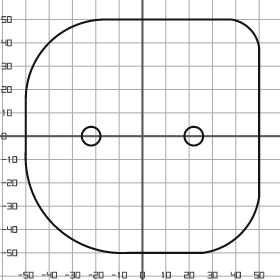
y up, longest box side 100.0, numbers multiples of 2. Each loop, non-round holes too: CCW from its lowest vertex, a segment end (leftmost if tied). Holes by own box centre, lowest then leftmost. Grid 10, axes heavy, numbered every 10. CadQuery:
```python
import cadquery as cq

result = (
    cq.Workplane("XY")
    .moveTo(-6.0, -50.0)
    .lineTo(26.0, -50.0)
    .threePointArc((42.0, -42.0), (50.0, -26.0))
    .lineTo(50.0, 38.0)
    .threePointArc((46.0, 46.0), (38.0, 50.0))
    .lineTo(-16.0, 50.0)
    .threePointArc((-40.0, 40.0), (-50.0, 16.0))
    .lineTo(-50.0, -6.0)
    .threePointArc((-38.0, -38.0), (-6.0, -50.0))
    .close()
    .moveTo(-22.0, 0.0)
    .circle(4.0)
    .moveTo(22.0, 0.0)
    .circle(4.0)
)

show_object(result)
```